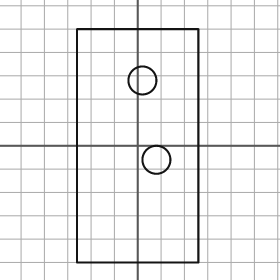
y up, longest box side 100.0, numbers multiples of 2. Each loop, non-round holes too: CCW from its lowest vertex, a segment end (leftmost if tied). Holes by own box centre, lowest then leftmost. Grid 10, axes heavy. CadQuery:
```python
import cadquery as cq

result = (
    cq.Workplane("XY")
    .moveTo(-26.0, -50.0)
    .lineTo(26.0, -50.0)
    .lineTo(26.0, 50.0)
    .lineTo(-26.0, 50.0)
    .close()
    .moveTo(8.0, -6.0)
    .circle(6.0)
    .moveTo(2.0, 28.0)
    .circle(6.0)
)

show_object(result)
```